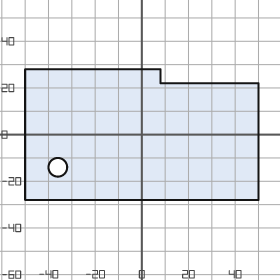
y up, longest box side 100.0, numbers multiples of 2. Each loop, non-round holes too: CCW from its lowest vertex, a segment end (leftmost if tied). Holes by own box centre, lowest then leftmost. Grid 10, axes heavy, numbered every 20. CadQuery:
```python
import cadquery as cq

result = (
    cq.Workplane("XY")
    .moveTo(-50.0, -28.0)
    .lineTo(50.0, -28.0)
    .lineTo(50.0, 22.0)
    .lineTo(8.0, 22.0)
    .lineTo(8.0, 28.0)
    .lineTo(-50.0, 28.0)
    .close()
    .moveTo(-36.0, -14.0)
    .circle(4.0)
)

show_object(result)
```